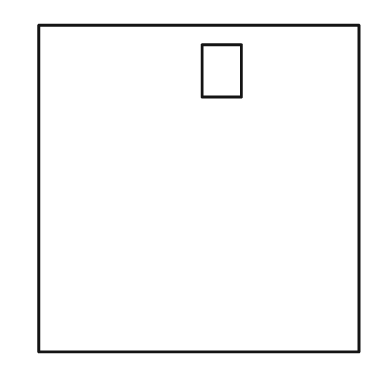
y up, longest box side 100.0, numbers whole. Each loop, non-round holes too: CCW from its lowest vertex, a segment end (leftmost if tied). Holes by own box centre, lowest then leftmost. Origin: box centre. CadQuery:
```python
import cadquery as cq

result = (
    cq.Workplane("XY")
    .moveTo(-49.0, -50.0)
    .lineTo(49.0, -50.0)
    .lineTo(49.0, 50.0)
    .lineTo(-49.0, 50.0)
    .close()
    .moveTo(1.0, 28.0)
    .lineTo(13.0, 28.0)
    .lineTo(13.0, 44.0)
    .lineTo(1.0, 44.0)
    .close()
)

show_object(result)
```